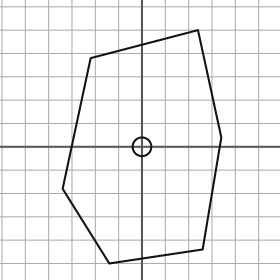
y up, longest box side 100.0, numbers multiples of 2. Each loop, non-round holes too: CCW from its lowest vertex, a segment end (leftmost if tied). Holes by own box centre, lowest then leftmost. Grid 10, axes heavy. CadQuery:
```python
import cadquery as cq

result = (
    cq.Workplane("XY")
    .moveTo(-14.0, -50.0)
    .lineTo(26.0, -44.0)
    .lineTo(34.0, 4.0)
    .lineTo(24.0, 50.0)
    .lineTo(-22.0, 38.0)
    .lineTo(-34.0, -18.0)
    .close()
    .moveTo(0.0, 0.0)
    .circle(4.0)
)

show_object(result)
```